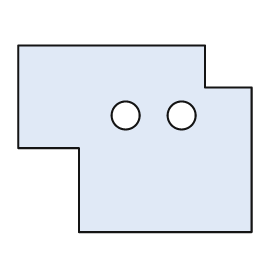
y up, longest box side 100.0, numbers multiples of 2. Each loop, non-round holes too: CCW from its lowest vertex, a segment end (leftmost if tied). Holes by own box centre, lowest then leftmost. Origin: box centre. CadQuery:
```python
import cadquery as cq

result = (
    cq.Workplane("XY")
    .moveTo(-24.0, -40.0)
    .lineTo(50.0, -40.0)
    .lineTo(50.0, 22.0)
    .lineTo(30.0, 22.0)
    .lineTo(30.0, 40.0)
    .lineTo(-50.0, 40.0)
    .lineTo(-50.0, -4.0)
    .lineTo(-24.0, -4.0)
    .close()
    .moveTo(-4.0, 10.0)
    .circle(6.0)
    .moveTo(20.0, 10.0)
    .circle(6.0)
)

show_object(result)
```